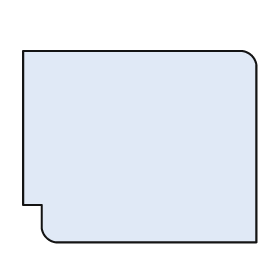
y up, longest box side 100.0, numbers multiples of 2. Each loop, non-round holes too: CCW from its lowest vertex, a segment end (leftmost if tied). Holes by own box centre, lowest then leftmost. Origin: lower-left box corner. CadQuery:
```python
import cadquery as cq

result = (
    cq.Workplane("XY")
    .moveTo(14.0, 0.0)
    .lineTo(100.0, 0.0)
    .lineTo(100.0, 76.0)
    .threePointArc((98.0, 80.0), (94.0, 82.0))
    .lineTo(0.0, 82.0)
    .lineTo(0.0, 16.0)
    .lineTo(8.0, 16.0)
    .lineTo(8.0, 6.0)
    .threePointArc((10.0, 2.0), (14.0, 0.0))
    .close()
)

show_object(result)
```